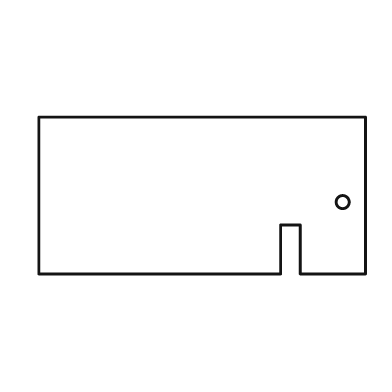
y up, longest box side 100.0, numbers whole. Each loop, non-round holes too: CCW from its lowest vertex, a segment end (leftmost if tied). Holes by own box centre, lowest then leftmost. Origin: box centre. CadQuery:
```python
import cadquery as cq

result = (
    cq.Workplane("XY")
    .moveTo(-50.0, -24.0)
    .lineTo(24.0, -24.0)
    .lineTo(24.0, -9.0)
    .lineTo(30.0, -9.0)
    .lineTo(30.0, -24.0)
    .lineTo(50.0, -24.0)
    .lineTo(50.0, 24.0)
    .lineTo(-50.0, 24.0)
    .close()
    .moveTo(43.0, -2.0)
    .circle(2.0)
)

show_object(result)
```